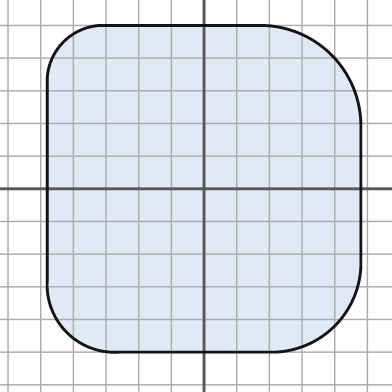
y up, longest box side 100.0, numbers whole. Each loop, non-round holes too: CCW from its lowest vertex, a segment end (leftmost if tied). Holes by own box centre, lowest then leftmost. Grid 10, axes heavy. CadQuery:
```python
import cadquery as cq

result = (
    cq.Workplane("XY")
    .moveTo(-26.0, -50.0)
    .lineTo(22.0, -50.0)
    .threePointArc((40.0, -42.0), (48.0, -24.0))
    .lineTo(48.0, 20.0)
    .threePointArc((39.0, 41.0), (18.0, 50.0))
    .lineTo(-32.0, 50.0)
    .threePointArc((-43.0, 45.0), (-48.0, 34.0))
    .lineTo(-48.0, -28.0)
    .threePointArc((-42.0, -44.0), (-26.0, -50.0))
    .close()
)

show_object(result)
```